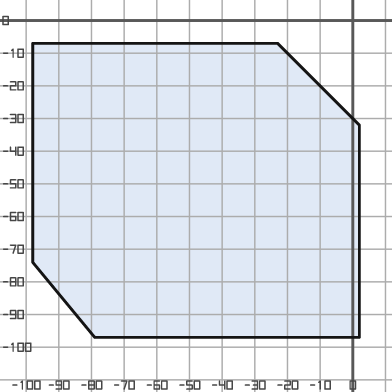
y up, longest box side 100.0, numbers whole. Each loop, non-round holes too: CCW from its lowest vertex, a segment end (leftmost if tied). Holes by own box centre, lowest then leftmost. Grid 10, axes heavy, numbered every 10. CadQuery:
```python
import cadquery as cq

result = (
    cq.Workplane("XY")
    .moveTo(-79.0, -97.0)
    .lineTo(2.0, -97.0)
    .lineTo(2.0, -32.0)
    .lineTo(-23.0, -7.0)
    .lineTo(-98.0, -7.0)
    .lineTo(-98.0, -74.0)
    .close()
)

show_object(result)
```